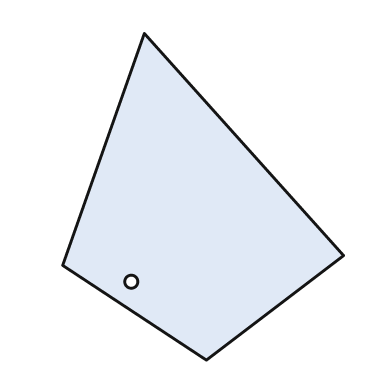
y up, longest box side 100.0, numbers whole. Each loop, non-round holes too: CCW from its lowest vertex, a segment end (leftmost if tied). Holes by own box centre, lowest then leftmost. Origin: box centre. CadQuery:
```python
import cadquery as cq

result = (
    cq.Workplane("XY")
    .moveTo(1.0, -50.0)
    .lineTo(43.0, -18.0)
    .lineTo(-18.0, 50.0)
    .lineTo(-43.0, -21.0)
    .close()
    .moveTo(-22.0, -26.0)
    .circle(2.0)
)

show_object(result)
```